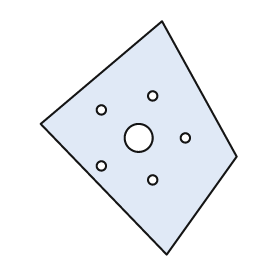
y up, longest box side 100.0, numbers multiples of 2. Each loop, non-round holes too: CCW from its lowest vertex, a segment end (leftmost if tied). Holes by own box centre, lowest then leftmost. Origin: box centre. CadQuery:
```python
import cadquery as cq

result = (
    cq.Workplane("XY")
    .moveTo(12.0, -50.0)
    .lineTo(42.0, -8.0)
    .lineTo(10.0, 50.0)
    .lineTo(-42.0, 6.0)
    .close()
    .moveTo(6.0, -18.0)
    .circle(2.0)
    .moveTo(-16.0, -12.0)
    .circle(2.0)
    .moveTo(0.0, 0.0)
    .circle(6.0)
    .moveTo(20.0, 0.0)
    .circle(2.0)
    .moveTo(-16.0, 12.0)
    .circle(2.0)
    .moveTo(6.0, 18.0)
    .circle(2.0)
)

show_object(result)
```